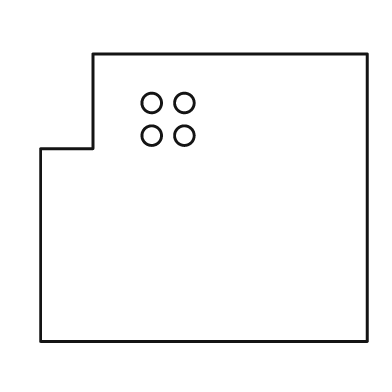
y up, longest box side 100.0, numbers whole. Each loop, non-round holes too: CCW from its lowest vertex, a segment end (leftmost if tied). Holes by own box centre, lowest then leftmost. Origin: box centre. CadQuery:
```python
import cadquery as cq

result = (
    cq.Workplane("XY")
    .moveTo(-50.0, -44.0)
    .lineTo(50.0, -44.0)
    .lineTo(50.0, 44.0)
    .lineTo(-34.0, 44.0)
    .lineTo(-34.0, 15.0)
    .lineTo(-50.0, 15.0)
    .close()
    .moveTo(-16.0, 19.0)
    .circle(3.0)
    .moveTo(-6.0, 19.0)
    .circle(3.0)
    .moveTo(-16.0, 29.0)
    .circle(3.0)
    .moveTo(-6.0, 29.0)
    .circle(3.0)
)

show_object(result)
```